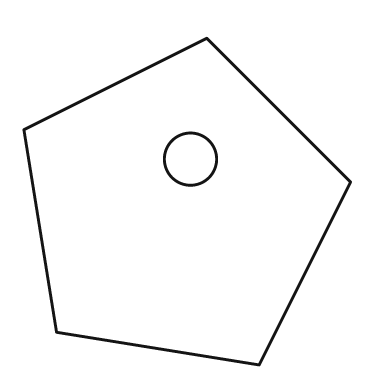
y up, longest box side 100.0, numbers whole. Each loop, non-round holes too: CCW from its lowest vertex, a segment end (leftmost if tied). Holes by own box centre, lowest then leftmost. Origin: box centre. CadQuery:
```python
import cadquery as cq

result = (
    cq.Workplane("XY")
    .moveTo(22.0, -50.0)
    .lineTo(50.0, 6.0)
    .lineTo(6.0, 50.0)
    .lineTo(-50.0, 22.0)
    .lineTo(-40.0, -40.0)
    .close()
    .moveTo(1.0, 13.0)
    .circle(8.0)
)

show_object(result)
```